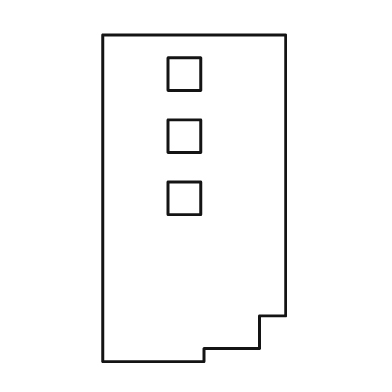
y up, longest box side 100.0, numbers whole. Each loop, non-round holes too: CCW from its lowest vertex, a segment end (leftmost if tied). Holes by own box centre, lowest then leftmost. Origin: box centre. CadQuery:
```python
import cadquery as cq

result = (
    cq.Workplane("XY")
    .moveTo(-28.0, -50.0)
    .lineTo(3.0, -50.0)
    .lineTo(3.0, -46.0)
    .lineTo(20.0, -46.0)
    .lineTo(20.0, -36.0)
    .lineTo(28.0, -36.0)
    .lineTo(28.0, 50.0)
    .lineTo(-28.0, 50.0)
    .close()
    .moveTo(-8.0, -5.0)
    .lineTo(2.0, -5.0)
    .lineTo(2.0, 5.0)
    .lineTo(-8.0, 5.0)
    .close()
    .moveTo(-8.0, 14.0)
    .lineTo(2.0, 14.0)
    .lineTo(2.0, 24.0)
    .lineTo(-8.0, 24.0)
    .close()
    .moveTo(-8.0, 33.0)
    .lineTo(2.0, 33.0)
    .lineTo(2.0, 43.0)
    .lineTo(-8.0, 43.0)
    .close()
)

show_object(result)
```